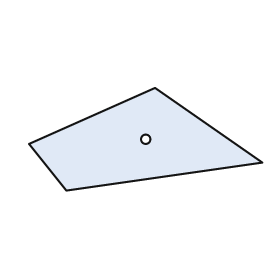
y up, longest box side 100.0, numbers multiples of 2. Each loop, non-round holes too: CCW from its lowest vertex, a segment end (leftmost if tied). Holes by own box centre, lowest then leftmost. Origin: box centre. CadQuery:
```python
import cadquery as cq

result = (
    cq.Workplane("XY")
    .moveTo(-34.0, -22.0)
    .lineTo(50.0, -10.0)
    .lineTo(4.0, 22.0)
    .lineTo(-50.0, -2.0)
    .close()
    .moveTo(0.0, 0.0)
    .circle(2.0)
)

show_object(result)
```